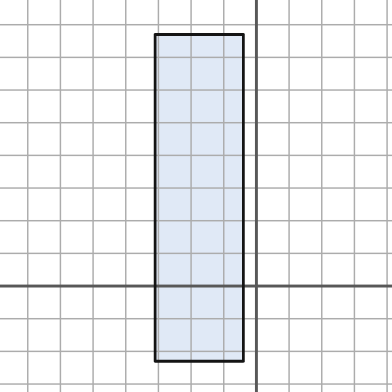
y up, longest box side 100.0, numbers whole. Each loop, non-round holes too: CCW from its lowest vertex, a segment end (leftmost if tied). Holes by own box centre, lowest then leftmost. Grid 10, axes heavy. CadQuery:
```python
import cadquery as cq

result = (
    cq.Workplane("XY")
    .moveTo(-31.0, -23.0)
    .lineTo(-4.0, -23.0)
    .lineTo(-4.0, 77.0)
    .lineTo(-31.0, 77.0)
    .close()
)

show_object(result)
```